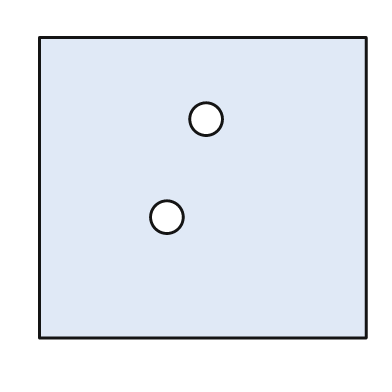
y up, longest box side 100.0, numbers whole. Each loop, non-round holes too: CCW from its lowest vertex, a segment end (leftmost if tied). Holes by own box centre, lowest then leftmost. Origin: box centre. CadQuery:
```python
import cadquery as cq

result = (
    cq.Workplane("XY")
    .moveTo(-50.0, -46.0)
    .lineTo(50.0, -46.0)
    .lineTo(50.0, 46.0)
    .lineTo(-50.0, 46.0)
    .close()
    .moveTo(-11.0, -9.0)
    .circle(5.0)
    .moveTo(1.0, 21.0)
    .circle(5.0)
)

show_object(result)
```